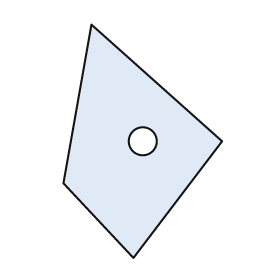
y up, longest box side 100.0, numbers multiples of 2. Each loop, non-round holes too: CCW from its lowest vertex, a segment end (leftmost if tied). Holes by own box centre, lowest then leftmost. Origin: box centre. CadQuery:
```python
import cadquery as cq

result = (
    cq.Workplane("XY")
    .moveTo(-4.0, -50.0)
    .lineTo(34.0, 0.0)
    .lineTo(-22.0, 50.0)
    .lineTo(-34.0, -18.0)
    .close()
    .moveTo(0.0, 0.0)
    .circle(6.0)
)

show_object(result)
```